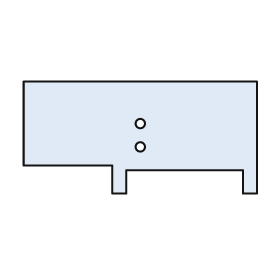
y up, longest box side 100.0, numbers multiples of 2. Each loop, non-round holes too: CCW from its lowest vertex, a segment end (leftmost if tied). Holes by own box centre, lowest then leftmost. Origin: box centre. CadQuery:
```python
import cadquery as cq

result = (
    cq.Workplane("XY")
    .moveTo(-12.0, -24.0)
    .lineTo(-6.0, -24.0)
    .lineTo(-6.0, -14.0)
    .lineTo(44.0, -14.0)
    .lineTo(44.0, -24.0)
    .lineTo(50.0, -24.0)
    .lineTo(50.0, 24.0)
    .lineTo(-50.0, 24.0)
    .lineTo(-50.0, -12.0)
    .lineTo(-12.0, -12.0)
    .close()
    .moveTo(0.0, -4.0)
    .circle(2.0)
    .moveTo(0.0, 6.0)
    .circle(2.0)
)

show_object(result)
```